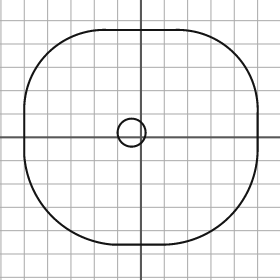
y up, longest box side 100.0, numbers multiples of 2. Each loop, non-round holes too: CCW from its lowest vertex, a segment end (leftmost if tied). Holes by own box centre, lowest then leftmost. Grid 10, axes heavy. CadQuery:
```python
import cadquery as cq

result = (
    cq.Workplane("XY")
    .moveTo(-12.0, -46.0)
    .lineTo(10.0, -46.0)
    .threePointArc((38.0, -34.0), (50.0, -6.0))
    .lineTo(50.0, 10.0)
    .threePointArc((40.0, 36.0), (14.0, 46.0))
    .lineTo(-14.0, 46.0)
    .threePointArc((-40.0, 36.0), (-50.0, 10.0))
    .lineTo(-50.0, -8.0)
    .threePointArc((-38.0, -34.0), (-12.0, -46.0))
    .close()
    .moveTo(-4.0, 2.0)
    .circle(6.0)
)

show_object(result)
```